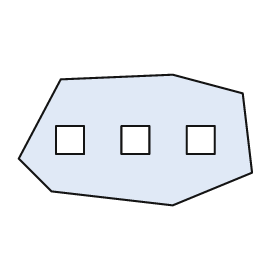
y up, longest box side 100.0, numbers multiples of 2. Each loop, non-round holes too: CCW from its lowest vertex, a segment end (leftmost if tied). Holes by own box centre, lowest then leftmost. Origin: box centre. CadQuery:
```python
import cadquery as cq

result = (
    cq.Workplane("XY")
    .moveTo(16.0, -28.0)
    .lineTo(50.0, -14.0)
    .lineTo(46.0, 20.0)
    .lineTo(16.0, 28.0)
    .lineTo(-32.0, 26.0)
    .lineTo(-50.0, -8.0)
    .lineTo(-36.0, -22.0)
    .close()
    .moveTo(-34.0, -6.0)
    .lineTo(-22.0, -6.0)
    .lineTo(-22.0, 6.0)
    .lineTo(-34.0, 6.0)
    .close()
    .moveTo(-6.0, -6.0)
    .lineTo(6.0, -6.0)
    .lineTo(6.0, 6.0)
    .lineTo(-6.0, 6.0)
    .close()
    .moveTo(22.0, -6.0)
    .lineTo(34.0, -6.0)
    .lineTo(34.0, 6.0)
    .lineTo(22.0, 6.0)
    .close()
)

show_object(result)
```